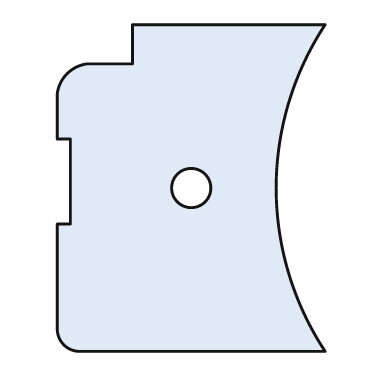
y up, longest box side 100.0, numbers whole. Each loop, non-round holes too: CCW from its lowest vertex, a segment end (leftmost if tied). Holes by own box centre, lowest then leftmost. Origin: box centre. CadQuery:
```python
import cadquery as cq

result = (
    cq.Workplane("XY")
    .moveTo(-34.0, -50.0)
    .lineTo(41.0, -50.0)
    .threePointArc((26.0, 0.0), (41.0, 50.0))
    .lineTo(-18.0, 50.0)
    .lineTo(-18.0, 38.0)
    .lineTo(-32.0, 38.0)
    .threePointArc((-38.0, 35.0), (-41.0, 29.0))
    .lineTo(-41.0, 15.0)
    .lineTo(-37.0, 15.0)
    .lineTo(-37.0, -11.0)
    .lineTo(-41.0, -11.0)
    .lineTo(-41.0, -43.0)
    .threePointArc((-39.0, -48.0), (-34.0, -50.0))
    .close()
    .moveTo(0.0, 0.0)
    .circle(6.0)
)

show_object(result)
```